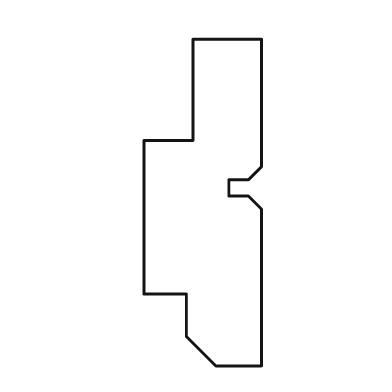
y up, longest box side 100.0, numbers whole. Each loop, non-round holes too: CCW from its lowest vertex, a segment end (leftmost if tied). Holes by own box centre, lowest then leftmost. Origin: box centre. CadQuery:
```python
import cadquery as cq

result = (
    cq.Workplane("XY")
    .moveTo(4.0, -50.0)
    .lineTo(18.0, -50.0)
    .lineTo(18.0, -2.0)
    .lineTo(14.0, 2.0)
    .lineTo(8.0, 2.0)
    .lineTo(8.0, 7.0)
    .lineTo(14.0, 7.0)
    .lineTo(18.0, 11.0)
    .lineTo(18.0, 50.0)
    .lineTo(-3.0, 50.0)
    .lineTo(-3.0, 19.0)
    .lineTo(-18.0, 19.0)
    .lineTo(-18.0, -28.0)
    .lineTo(-5.0, -28.0)
    .lineTo(-5.0, -41.0)
    .close()
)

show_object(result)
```